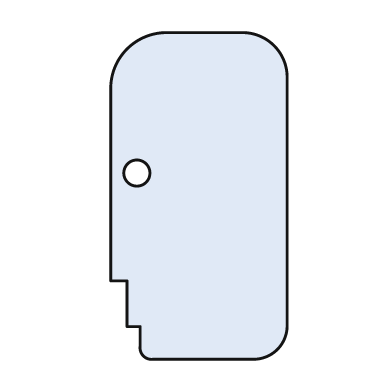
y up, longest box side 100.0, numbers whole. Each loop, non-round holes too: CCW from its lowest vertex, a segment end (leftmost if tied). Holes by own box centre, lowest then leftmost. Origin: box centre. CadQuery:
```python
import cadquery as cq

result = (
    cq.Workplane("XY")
    .moveTo(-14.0, -50.0)
    .lineTo(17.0, -50.0)
    .threePointArc((24.0, -47.0), (27.0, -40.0))
    .lineTo(27.0, 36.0)
    .threePointArc((23.0, 46.0), (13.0, 50.0))
    .lineTo(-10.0, 50.0)
    .threePointArc((-22.0, 45.0), (-27.0, 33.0))
    .lineTo(-27.0, -26.0)
    .lineTo(-22.0, -26.0)
    .lineTo(-22.0, -40.0)
    .lineTo(-18.0, -40.0)
    .lineTo(-18.0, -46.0)
    .threePointArc((-17.0, -49.0), (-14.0, -50.0))
    .close()
    .moveTo(-19.0, 7.0)
    .circle(4.0)
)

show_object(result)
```